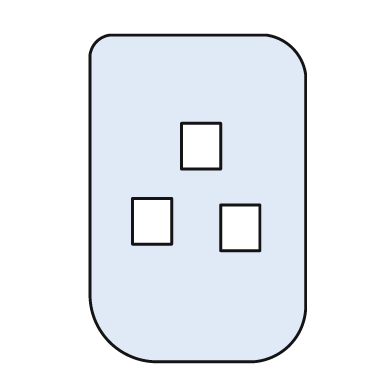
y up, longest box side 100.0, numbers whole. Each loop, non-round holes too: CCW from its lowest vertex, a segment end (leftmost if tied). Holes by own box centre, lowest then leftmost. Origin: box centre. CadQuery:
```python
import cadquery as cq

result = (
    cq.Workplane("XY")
    .moveTo(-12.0, -50.0)
    .lineTo(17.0, -50.0)
    .threePointArc((28.0, -45.0), (33.0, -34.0))
    .lineTo(33.0, 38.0)
    .threePointArc((29.0, 46.0), (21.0, 50.0))
    .lineTo(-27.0, 50.0)
    .threePointArc((-31.0, 48.0), (-33.0, 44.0))
    .lineTo(-33.0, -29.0)
    .threePointArc((-27.0, -44.0), (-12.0, -50.0))
    .close()
    .moveTo(7.0, -16.0)
    .lineTo(19.0, -16.0)
    .lineTo(19.0, -2.0)
    .lineTo(7.0, -2.0)
    .close()
    .moveTo(-20.0, -14.0)
    .lineTo(-8.0, -14.0)
    .lineTo(-8.0, 0.0)
    .lineTo(-20.0, 0.0)
    .close()
    .moveTo(-5.0, 9.0)
    .lineTo(7.0, 9.0)
    .lineTo(7.0, 23.0)
    .lineTo(-5.0, 23.0)
    .close()
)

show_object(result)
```